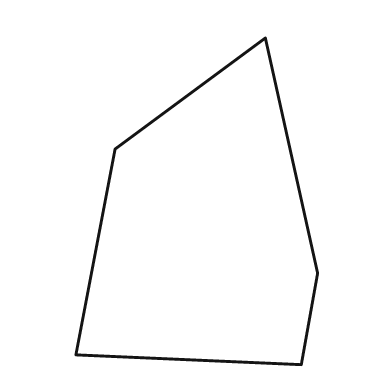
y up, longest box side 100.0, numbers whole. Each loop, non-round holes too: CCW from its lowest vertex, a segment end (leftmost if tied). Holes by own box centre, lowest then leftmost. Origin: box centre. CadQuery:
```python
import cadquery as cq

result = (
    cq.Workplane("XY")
    .moveTo(32.0, -50.0)
    .lineTo(37.0, -22.0)
    .lineTo(21.0, 50.0)
    .lineTo(-25.0, 16.0)
    .lineTo(-37.0, -47.0)
    .close()
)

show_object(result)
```